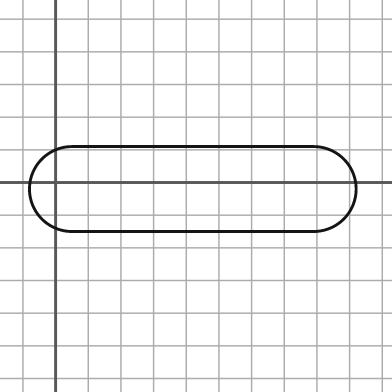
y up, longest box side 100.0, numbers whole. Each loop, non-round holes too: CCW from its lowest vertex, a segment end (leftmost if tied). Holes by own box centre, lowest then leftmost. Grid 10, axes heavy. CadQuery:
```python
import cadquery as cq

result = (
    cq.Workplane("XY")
    .moveTo(5.0, -15.0)
    .lineTo(79.0, -15.0)
    .threePointArc((92.0, -2.0), (79.0, 11.0))
    .lineTo(5.0, 11.0)
    .threePointArc((-8.0, -2.0), (5.0, -15.0))
    .close()
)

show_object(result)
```